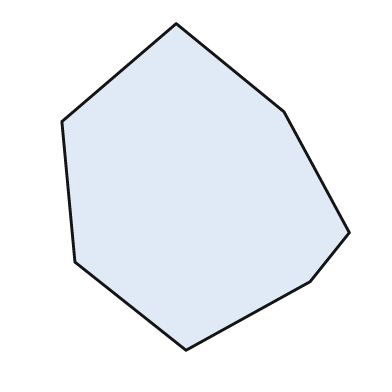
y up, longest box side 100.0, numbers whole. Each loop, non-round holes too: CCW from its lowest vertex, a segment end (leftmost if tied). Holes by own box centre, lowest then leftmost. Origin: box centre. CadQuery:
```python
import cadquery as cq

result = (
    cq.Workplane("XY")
    .moveTo(-6.0, -50.0)
    .lineTo(32.0, -29.0)
    .lineTo(44.0, -14.0)
    .lineTo(24.0, 23.0)
    .lineTo(-9.0, 50.0)
    .lineTo(-44.0, 20.0)
    .lineTo(-40.0, -23.0)
    .close()
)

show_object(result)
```